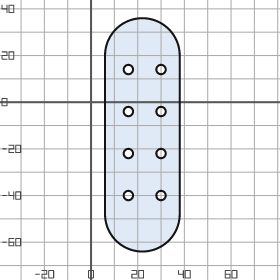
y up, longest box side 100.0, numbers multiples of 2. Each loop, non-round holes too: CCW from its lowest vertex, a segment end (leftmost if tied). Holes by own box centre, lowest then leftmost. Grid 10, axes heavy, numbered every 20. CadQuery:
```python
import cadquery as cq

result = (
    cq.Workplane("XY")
    .moveTo(6.0, -48.0)
    .threePointArc((22.0, -64.0), (38.0, -48.0))
    .lineTo(38.0, 20.0)
    .threePointArc((22.0, 36.0), (6.0, 20.0))
    .close()
    .moveTo(16.0, -40.0)
    .circle(2.0)
    .moveTo(30.0, -40.0)
    .circle(2.0)
    .moveTo(16.0, -22.0)
    .circle(2.0)
    .moveTo(30.0, -22.0)
    .circle(2.0)
    .moveTo(16.0, -4.0)
    .circle(2.0)
    .moveTo(30.0, -4.0)
    .circle(2.0)
    .moveTo(16.0, 14.0)
    .circle(2.0)
    .moveTo(30.0, 14.0)
    .circle(2.0)
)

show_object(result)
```